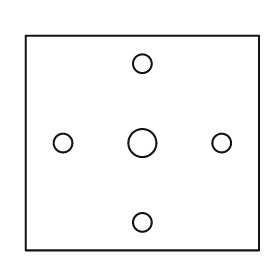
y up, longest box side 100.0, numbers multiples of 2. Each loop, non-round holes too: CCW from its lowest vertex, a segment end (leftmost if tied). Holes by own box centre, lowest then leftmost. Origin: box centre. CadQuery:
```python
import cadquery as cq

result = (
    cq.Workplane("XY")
    .moveTo(-50.0, -46.0)
    .lineTo(50.0, -46.0)
    .lineTo(50.0, 46.0)
    .lineTo(-50.0, 46.0)
    .close()
    .moveTo(0.0, -34.0)
    .circle(4.0)
    .moveTo(-34.0, 0.0)
    .circle(4.0)
    .moveTo(0.0, 0.0)
    .circle(6.0)
    .moveTo(34.0, 0.0)
    .circle(4.0)
    .moveTo(0.0, 34.0)
    .circle(4.0)
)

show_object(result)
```